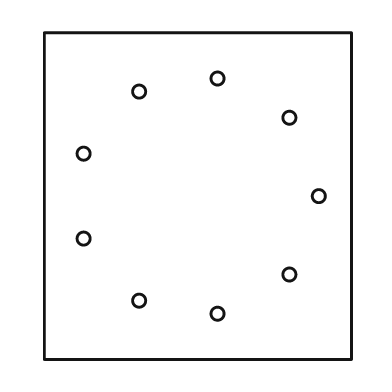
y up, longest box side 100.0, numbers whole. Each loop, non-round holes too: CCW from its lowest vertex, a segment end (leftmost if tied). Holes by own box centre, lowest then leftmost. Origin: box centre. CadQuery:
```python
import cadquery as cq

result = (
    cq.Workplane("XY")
    .moveTo(-47.0, -50.0)
    .lineTo(47.0, -50.0)
    .lineTo(47.0, 50.0)
    .lineTo(-47.0, 50.0)
    .close()
    .moveTo(6.0, -36.0)
    .circle(2.0)
    .moveTo(-18.0, -32.0)
    .circle(2.0)
    .moveTo(28.0, -24.0)
    .circle(2.0)
    .moveTo(-35.0, -13.0)
    .circle(2.0)
    .moveTo(37.0, 0.0)
    .circle(2.0)
    .moveTo(-35.0, 13.0)
    .circle(2.0)
    .moveTo(28.0, 24.0)
    .circle(2.0)
    .moveTo(-18.0, 32.0)
    .circle(2.0)
    .moveTo(6.0, 36.0)
    .circle(2.0)
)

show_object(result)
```